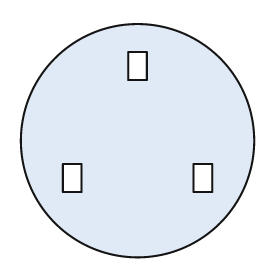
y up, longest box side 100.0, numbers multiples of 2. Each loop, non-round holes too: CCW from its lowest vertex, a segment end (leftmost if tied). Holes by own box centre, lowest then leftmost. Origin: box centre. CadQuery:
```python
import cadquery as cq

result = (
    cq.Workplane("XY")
    .moveTo(0.0, 0.0)
    .circle(50.0)
    .moveTo(-32.0, -22.0)
    .lineTo(-24.0, -22.0)
    .lineTo(-24.0, -10.0)
    .lineTo(-32.0, -10.0)
    .close()
    .moveTo(24.0, -22.0)
    .lineTo(32.0, -22.0)
    .lineTo(32.0, -10.0)
    .lineTo(24.0, -10.0)
    .close()
    .moveTo(-4.0, 26.0)
    .lineTo(4.0, 26.0)
    .lineTo(4.0, 38.0)
    .lineTo(-4.0, 38.0)
    .close()
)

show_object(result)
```